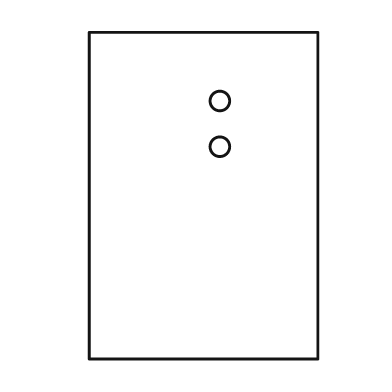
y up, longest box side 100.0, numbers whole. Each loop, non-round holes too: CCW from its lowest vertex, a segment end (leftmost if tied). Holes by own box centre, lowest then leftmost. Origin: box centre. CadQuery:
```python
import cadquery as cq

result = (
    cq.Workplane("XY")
    .moveTo(-35.0, -50.0)
    .lineTo(35.0, -50.0)
    .lineTo(35.0, 50.0)
    .lineTo(-35.0, 50.0)
    .close()
    .moveTo(5.0, 15.0)
    .circle(3.0)
    .moveTo(5.0, 29.0)
    .circle(3.0)
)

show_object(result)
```